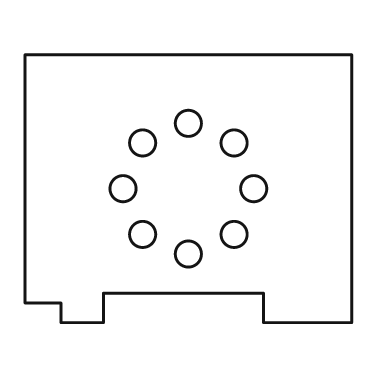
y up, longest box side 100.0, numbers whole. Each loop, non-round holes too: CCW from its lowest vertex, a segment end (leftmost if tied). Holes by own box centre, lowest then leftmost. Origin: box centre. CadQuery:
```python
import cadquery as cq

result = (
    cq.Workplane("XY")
    .moveTo(-39.0, -41.0)
    .lineTo(-26.0, -41.0)
    .lineTo(-26.0, -32.0)
    .lineTo(23.0, -32.0)
    .lineTo(23.0, -41.0)
    .lineTo(50.0, -41.0)
    .lineTo(50.0, 41.0)
    .lineTo(-50.0, 41.0)
    .lineTo(-50.0, -35.0)
    .lineTo(-39.0, -35.0)
    .close()
    .moveTo(0.0, -20.0)
    .circle(4.0)
    .moveTo(-14.0, -14.0)
    .circle(4.0)
    .moveTo(14.0, -14.0)
    .circle(4.0)
    .moveTo(-20.0, 0.0)
    .circle(4.0)
    .moveTo(20.0, 0.0)
    .circle(4.0)
    .moveTo(-14.0, 14.0)
    .circle(4.0)
    .moveTo(14.0, 14.0)
    .circle(4.0)
    .moveTo(0.0, 20.0)
    .circle(4.0)
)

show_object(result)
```